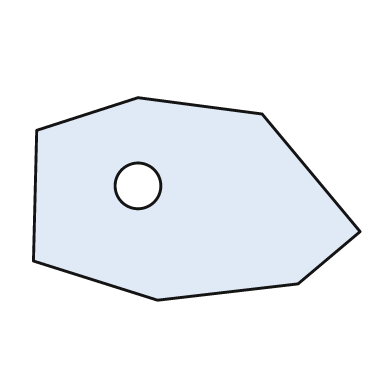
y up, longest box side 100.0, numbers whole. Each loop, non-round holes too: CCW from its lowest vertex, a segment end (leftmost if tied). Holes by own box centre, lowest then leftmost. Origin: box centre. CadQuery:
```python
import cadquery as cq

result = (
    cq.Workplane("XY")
    .moveTo(-12.0, -31.0)
    .lineTo(31.0, -26.0)
    .lineTo(50.0, -10.0)
    .lineTo(20.0, 26.0)
    .lineTo(-18.0, 31.0)
    .lineTo(-49.0, 21.0)
    .lineTo(-50.0, -19.0)
    .close()
    .moveTo(-18.0, 4.0)
    .circle(7.0)
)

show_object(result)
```